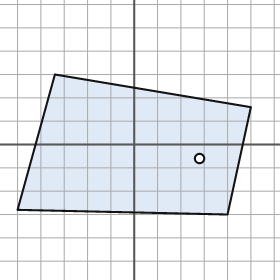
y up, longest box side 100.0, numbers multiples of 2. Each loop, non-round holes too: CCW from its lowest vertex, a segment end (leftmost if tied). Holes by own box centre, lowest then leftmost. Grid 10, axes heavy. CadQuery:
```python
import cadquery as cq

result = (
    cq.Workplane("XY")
    .moveTo(40.0, -30.0)
    .lineTo(50.0, 16.0)
    .lineTo(-34.0, 30.0)
    .lineTo(-50.0, -28.0)
    .close()
    .moveTo(28.0, -6.0)
    .circle(2.0)
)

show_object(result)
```